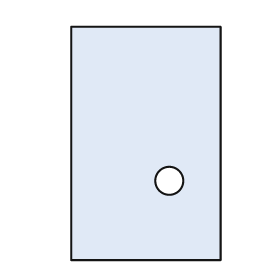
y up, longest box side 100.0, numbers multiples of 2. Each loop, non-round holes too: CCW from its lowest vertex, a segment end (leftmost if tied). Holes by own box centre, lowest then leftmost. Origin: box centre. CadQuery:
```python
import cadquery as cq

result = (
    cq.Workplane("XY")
    .moveTo(-32.0, -50.0)
    .lineTo(32.0, -50.0)
    .lineTo(32.0, 50.0)
    .lineTo(-32.0, 50.0)
    .close()
    .moveTo(10.0, -16.0)
    .circle(6.0)
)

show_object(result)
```